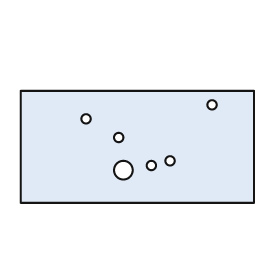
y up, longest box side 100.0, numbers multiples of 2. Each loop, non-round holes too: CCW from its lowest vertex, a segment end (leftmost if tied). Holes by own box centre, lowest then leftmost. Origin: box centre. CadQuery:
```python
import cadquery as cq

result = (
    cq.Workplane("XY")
    .moveTo(-50.0, -24.0)
    .lineTo(50.0, -24.0)
    .lineTo(50.0, 24.0)
    .lineTo(-50.0, 24.0)
    .close()
    .moveTo(-6.0, -10.0)
    .circle(4.0)
    .moveTo(6.0, -8.0)
    .circle(2.0)
    .moveTo(14.0, -6.0)
    .circle(2.0)
    .moveTo(-8.0, 4.0)
    .circle(2.0)
    .moveTo(-22.0, 12.0)
    .circle(2.0)
    .moveTo(32.0, 18.0)
    .circle(2.0)
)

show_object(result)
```